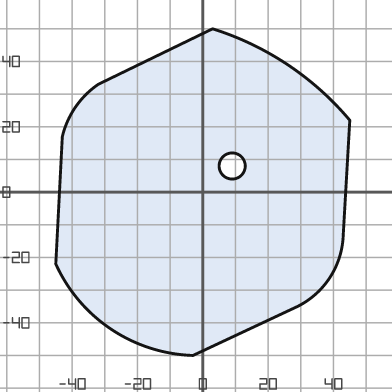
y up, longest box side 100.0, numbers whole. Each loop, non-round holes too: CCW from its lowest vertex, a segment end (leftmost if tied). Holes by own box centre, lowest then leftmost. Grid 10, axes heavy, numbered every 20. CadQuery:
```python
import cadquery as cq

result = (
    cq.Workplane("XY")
    .moveTo(-3.0, -50.0)
    .lineTo(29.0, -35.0)
    .threePointArc((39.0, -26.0), (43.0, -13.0))
    .lineTo(45.0, 22.0)
    .threePointArc((26.0, 39.0), (3.0, 50.0))
    .lineTo(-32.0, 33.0)
    .threePointArc((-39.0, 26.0), (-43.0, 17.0))
    .lineTo(-45.0, -22.0)
    .threePointArc((-28.0, -42.0), (-3.0, -50.0))
    .close()
    .moveTo(9.0, 8.0)
    .circle(4.0)
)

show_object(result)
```